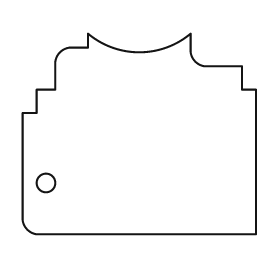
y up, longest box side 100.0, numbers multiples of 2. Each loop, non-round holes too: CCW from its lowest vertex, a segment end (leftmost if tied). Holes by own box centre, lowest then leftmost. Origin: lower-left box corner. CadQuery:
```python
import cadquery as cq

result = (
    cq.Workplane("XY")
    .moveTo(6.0, 0.0)
    .lineTo(100.0, 0.0)
    .lineTo(100.0, 62.0)
    .lineTo(94.0, 62.0)
    .lineTo(94.0, 72.0)
    .lineTo(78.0, 72.0)
    .threePointArc((74.0, 74.0), (72.0, 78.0))
    .lineTo(72.0, 86.0)
    .threePointArc((50.0, 78.0), (28.0, 86.0))
    .lineTo(28.0, 80.0)
    .lineTo(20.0, 80.0)
    .threePointArc((16.0, 78.0), (14.0, 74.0))
    .lineTo(14.0, 62.0)
    .lineTo(6.0, 62.0)
    .lineTo(6.0, 52.0)
    .lineTo(0.0, 52.0)
    .lineTo(0.0, 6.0)
    .threePointArc((2.0, 2.0), (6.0, 0.0))
    .close()
    .moveTo(10.0, 22.0)
    .circle(4.0)
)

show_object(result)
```